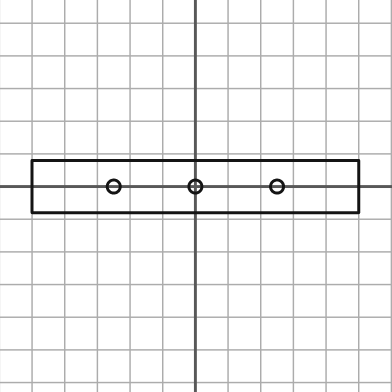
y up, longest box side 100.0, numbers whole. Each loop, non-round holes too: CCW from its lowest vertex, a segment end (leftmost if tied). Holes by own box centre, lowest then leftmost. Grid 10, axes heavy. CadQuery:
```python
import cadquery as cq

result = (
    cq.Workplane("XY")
    .moveTo(-50.0, -8.0)
    .lineTo(50.0, -8.0)
    .lineTo(50.0, 8.0)
    .lineTo(-50.0, 8.0)
    .close()
    .moveTo(-25.0, 0.0)
    .circle(2.0)
    .moveTo(0.0, 0.0)
    .circle(2.0)
    .moveTo(25.0, 0.0)
    .circle(2.0)
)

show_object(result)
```